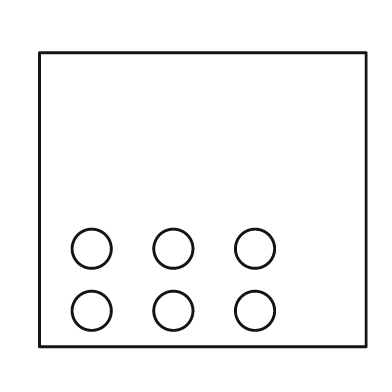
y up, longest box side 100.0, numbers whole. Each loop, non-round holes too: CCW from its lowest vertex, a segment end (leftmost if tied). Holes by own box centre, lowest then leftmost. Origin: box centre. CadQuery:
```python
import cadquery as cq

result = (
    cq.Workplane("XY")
    .moveTo(-50.0, -45.0)
    .lineTo(50.0, -45.0)
    .lineTo(50.0, 45.0)
    .lineTo(-50.0, 45.0)
    .close()
    .moveTo(-34.0, -34.0)
    .circle(6.0)
    .moveTo(-9.0, -34.0)
    .circle(6.0)
    .moveTo(16.0, -34.0)
    .circle(6.0)
    .moveTo(-34.0, -15.0)
    .circle(6.0)
    .moveTo(-9.0, -15.0)
    .circle(6.0)
    .moveTo(16.0, -15.0)
    .circle(6.0)
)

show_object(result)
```